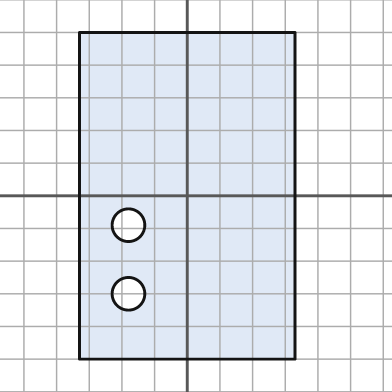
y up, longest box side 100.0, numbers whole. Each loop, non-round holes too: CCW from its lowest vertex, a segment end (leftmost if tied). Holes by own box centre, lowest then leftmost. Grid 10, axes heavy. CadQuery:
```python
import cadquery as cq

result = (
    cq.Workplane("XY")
    .moveTo(-33.0, -50.0)
    .lineTo(33.0, -50.0)
    .lineTo(33.0, 50.0)
    .lineTo(-33.0, 50.0)
    .close()
    .moveTo(-18.0, -30.0)
    .circle(5.0)
    .moveTo(-18.0, -9.0)
    .circle(5.0)
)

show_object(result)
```